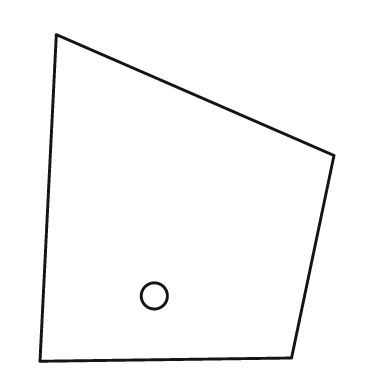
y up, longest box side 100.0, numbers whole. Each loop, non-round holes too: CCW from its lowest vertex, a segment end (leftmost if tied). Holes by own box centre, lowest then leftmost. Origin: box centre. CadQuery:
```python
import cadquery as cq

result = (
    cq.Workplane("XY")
    .moveTo(-45.0, -50.0)
    .lineTo(32.0, -49.0)
    .lineTo(45.0, 13.0)
    .lineTo(-40.0, 50.0)
    .close()
    .moveTo(-10.0, -30.0)
    .circle(4.0)
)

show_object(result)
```